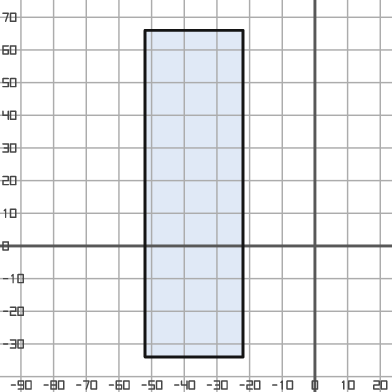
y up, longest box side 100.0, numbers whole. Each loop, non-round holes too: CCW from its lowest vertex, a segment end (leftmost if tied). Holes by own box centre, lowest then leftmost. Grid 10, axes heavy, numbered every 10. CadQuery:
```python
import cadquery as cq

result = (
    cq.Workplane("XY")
    .moveTo(-52.0, -34.0)
    .lineTo(-22.0, -34.0)
    .lineTo(-22.0, 66.0)
    .lineTo(-52.0, 66.0)
    .close()
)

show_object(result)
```